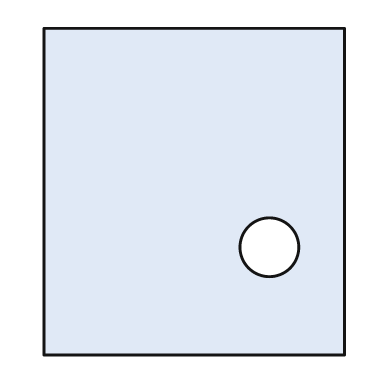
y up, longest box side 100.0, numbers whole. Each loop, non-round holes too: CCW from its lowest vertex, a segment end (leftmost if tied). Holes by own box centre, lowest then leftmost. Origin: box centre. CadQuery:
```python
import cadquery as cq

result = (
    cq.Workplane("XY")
    .moveTo(-46.0, -50.0)
    .lineTo(46.0, -50.0)
    .lineTo(46.0, 50.0)
    .lineTo(-46.0, 50.0)
    .close()
    .moveTo(23.0, -17.0)
    .circle(9.0)
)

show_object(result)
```